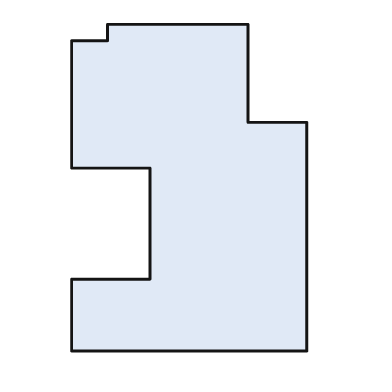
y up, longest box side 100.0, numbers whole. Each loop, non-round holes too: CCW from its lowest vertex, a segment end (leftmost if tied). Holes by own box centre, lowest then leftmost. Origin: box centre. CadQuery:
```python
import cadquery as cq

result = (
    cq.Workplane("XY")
    .moveTo(-36.0, -50.0)
    .lineTo(36.0, -50.0)
    .lineTo(36.0, 20.0)
    .lineTo(18.0, 20.0)
    .lineTo(18.0, 50.0)
    .lineTo(-25.0, 50.0)
    .lineTo(-25.0, 45.0)
    .lineTo(-36.0, 45.0)
    .lineTo(-36.0, 6.0)
    .lineTo(-12.0, 6.0)
    .lineTo(-12.0, -28.0)
    .lineTo(-36.0, -28.0)
    .close()
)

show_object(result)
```